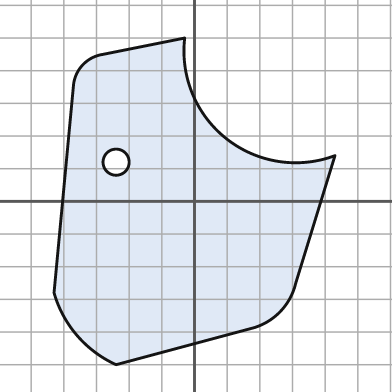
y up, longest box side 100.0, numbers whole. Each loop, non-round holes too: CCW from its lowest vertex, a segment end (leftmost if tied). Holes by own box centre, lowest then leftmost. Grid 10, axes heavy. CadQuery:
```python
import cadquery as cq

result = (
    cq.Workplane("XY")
    .moveTo(-24.0, -50.0)
    .lineTo(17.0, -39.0)
    .threePointArc((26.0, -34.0), (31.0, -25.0))
    .lineTo(43.0, 14.0)
    .threePointArc((10.0, 19.0), (-3.0, 50.0))
    .lineTo(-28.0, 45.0)
    .threePointArc((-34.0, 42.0), (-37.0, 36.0))
    .lineTo(-43.0, -28.0)
    .threePointArc((-36.0, -41.0), (-24.0, -50.0))
    .close()
    .moveTo(-24.0, 12.0)
    .circle(4.0)
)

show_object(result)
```